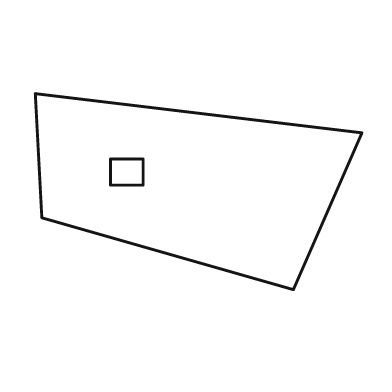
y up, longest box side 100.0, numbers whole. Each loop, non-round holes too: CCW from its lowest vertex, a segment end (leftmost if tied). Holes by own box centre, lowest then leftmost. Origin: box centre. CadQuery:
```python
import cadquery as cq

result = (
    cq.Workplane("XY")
    .moveTo(29.0, -30.0)
    .lineTo(50.0, 18.0)
    .lineTo(-50.0, 30.0)
    .lineTo(-48.0, -8.0)
    .close()
    .moveTo(-27.0, 2.0)
    .lineTo(-17.0, 2.0)
    .lineTo(-17.0, 10.0)
    .lineTo(-27.0, 10.0)
    .close()
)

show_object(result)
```